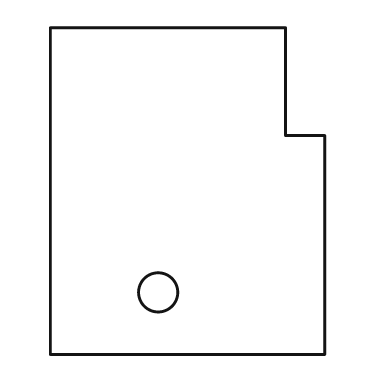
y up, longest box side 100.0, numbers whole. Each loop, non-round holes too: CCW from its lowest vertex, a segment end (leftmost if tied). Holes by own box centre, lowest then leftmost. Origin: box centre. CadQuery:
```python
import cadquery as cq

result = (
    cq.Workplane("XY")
    .moveTo(-42.0, -50.0)
    .lineTo(42.0, -50.0)
    .lineTo(42.0, 17.0)
    .lineTo(30.0, 17.0)
    .lineTo(30.0, 50.0)
    .lineTo(-42.0, 50.0)
    .close()
    .moveTo(-9.0, -31.0)
    .circle(6.0)
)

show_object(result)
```